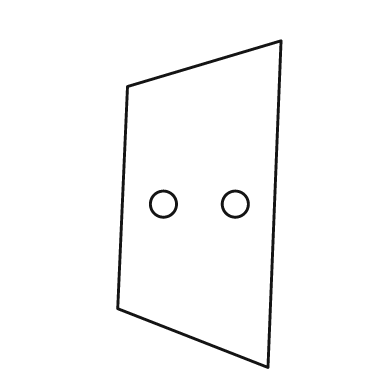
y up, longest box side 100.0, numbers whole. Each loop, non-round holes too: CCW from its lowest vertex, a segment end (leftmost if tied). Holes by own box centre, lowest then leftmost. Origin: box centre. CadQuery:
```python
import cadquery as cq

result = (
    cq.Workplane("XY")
    .moveTo(21.0, -50.0)
    .lineTo(25.0, 50.0)
    .lineTo(-22.0, 36.0)
    .lineTo(-25.0, -32.0)
    .close()
    .moveTo(-11.0, 0.0)
    .circle(4.0)
    .moveTo(11.0, 0.0)
    .circle(4.0)
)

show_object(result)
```